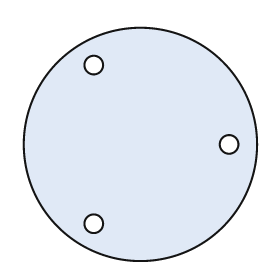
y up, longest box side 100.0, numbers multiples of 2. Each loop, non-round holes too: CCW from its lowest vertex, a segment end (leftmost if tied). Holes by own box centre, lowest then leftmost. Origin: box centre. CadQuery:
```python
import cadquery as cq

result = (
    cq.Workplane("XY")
    .moveTo(0.0, 0.0)
    .circle(50.0)
    .moveTo(-20.0, -34.0)
    .circle(4.0)
    .moveTo(38.0, 0.0)
    .circle(4.0)
    .moveTo(-20.0, 34.0)
    .circle(4.0)
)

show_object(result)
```